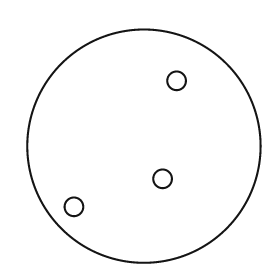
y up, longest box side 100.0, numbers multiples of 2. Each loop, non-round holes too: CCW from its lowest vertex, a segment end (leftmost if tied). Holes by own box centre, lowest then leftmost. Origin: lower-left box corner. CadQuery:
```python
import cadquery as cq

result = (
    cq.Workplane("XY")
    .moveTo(50.0, 50.0)
    .circle(50.0)
    .moveTo(20.0, 24.0)
    .circle(4.0)
    .moveTo(58.0, 36.0)
    .circle(4.0)
    .moveTo(64.0, 78.0)
    .circle(4.0)
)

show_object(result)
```